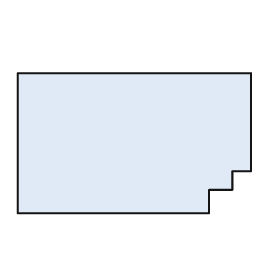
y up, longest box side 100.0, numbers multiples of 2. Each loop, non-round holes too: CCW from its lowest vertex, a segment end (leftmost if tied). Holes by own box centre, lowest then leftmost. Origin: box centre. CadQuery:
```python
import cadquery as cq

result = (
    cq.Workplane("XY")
    .moveTo(-50.0, -30.0)
    .lineTo(32.0, -30.0)
    .lineTo(32.0, -20.0)
    .lineTo(42.0, -20.0)
    .lineTo(42.0, -12.0)
    .lineTo(50.0, -12.0)
    .lineTo(50.0, 30.0)
    .lineTo(-50.0, 30.0)
    .close()
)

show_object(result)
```